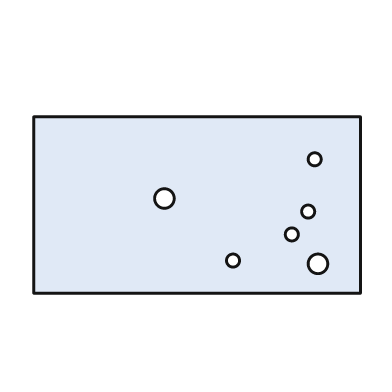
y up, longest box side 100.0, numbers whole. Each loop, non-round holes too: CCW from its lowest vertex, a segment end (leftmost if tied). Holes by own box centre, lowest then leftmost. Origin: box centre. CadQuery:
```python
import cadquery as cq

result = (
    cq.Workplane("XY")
    .moveTo(-50.0, -27.0)
    .lineTo(50.0, -27.0)
    .lineTo(50.0, 27.0)
    .lineTo(-50.0, 27.0)
    .close()
    .moveTo(37.0, -18.0)
    .circle(3.0)
    .moveTo(11.0, -17.0)
    .circle(2.0)
    .moveTo(29.0, -9.0)
    .circle(2.0)
    .moveTo(34.0, -2.0)
    .circle(2.0)
    .moveTo(-10.0, 2.0)
    .circle(3.0)
    .moveTo(36.0, 14.0)
    .circle(2.0)
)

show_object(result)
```